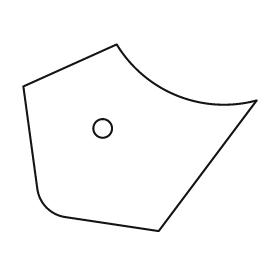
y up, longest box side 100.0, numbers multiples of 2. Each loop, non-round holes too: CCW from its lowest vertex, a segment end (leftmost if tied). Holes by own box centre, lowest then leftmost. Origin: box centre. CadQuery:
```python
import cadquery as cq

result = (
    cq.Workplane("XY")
    .moveTo(8.0, -40.0)
    .lineTo(50.0, 16.0)
    .threePointArc((16.0, 18.0), (-10.0, 40.0))
    .lineTo(-50.0, 22.0)
    .lineTo(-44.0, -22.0)
    .threePointArc((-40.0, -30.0), (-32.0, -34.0))
    .close()
    .moveTo(-16.0, 4.0)
    .circle(4.0)
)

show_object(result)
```